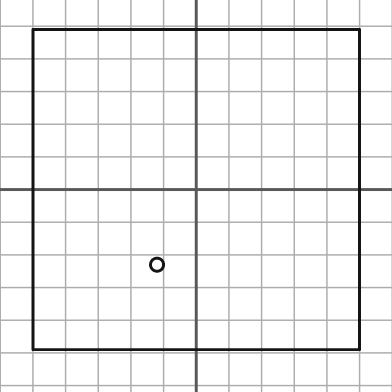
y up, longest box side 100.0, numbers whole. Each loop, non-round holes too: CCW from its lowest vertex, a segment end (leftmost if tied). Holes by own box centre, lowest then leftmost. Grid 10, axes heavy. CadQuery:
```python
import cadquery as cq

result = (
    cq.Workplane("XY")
    .moveTo(-50.0, -49.0)
    .lineTo(50.0, -49.0)
    .lineTo(50.0, 49.0)
    .lineTo(-50.0, 49.0)
    .close()
    .moveTo(-12.0, -23.0)
    .circle(2.0)
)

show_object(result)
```